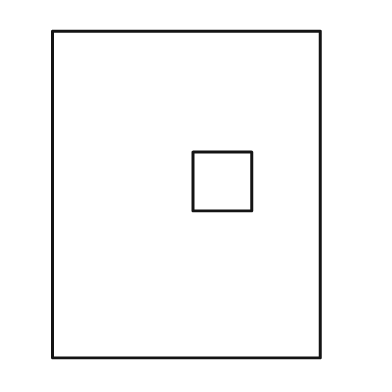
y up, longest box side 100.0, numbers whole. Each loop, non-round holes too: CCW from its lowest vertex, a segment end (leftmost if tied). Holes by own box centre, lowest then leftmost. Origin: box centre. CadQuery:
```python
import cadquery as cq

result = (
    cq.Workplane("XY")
    .moveTo(-41.0, -50.0)
    .lineTo(41.0, -50.0)
    .lineTo(41.0, 50.0)
    .lineTo(-41.0, 50.0)
    .close()
    .moveTo(2.0, -5.0)
    .lineTo(20.0, -5.0)
    .lineTo(20.0, 13.0)
    .lineTo(2.0, 13.0)
    .close()
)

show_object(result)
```